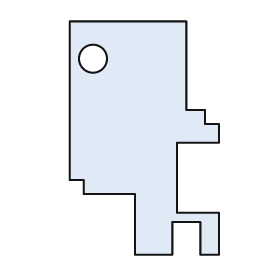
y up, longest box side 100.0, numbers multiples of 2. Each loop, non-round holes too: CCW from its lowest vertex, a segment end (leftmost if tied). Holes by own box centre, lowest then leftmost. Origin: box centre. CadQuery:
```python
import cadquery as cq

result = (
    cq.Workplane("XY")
    .moveTo(-4.0, -50.0)
    .lineTo(12.0, -50.0)
    .lineTo(12.0, -36.0)
    .lineTo(24.0, -36.0)
    .lineTo(24.0, -50.0)
    .lineTo(32.0, -50.0)
    .lineTo(32.0, -32.0)
    .lineTo(14.0, -32.0)
    .lineTo(14.0, -2.0)
    .lineTo(32.0, -2.0)
    .lineTo(32.0, 6.0)
    .lineTo(26.0, 6.0)
    .lineTo(26.0, 12.0)
    .lineTo(18.0, 12.0)
    .lineTo(18.0, 50.0)
    .lineTo(-32.0, 50.0)
    .lineTo(-32.0, -18.0)
    .lineTo(-26.0, -18.0)
    .lineTo(-26.0, -24.0)
    .lineTo(-4.0, -24.0)
    .close()
    .moveTo(-22.0, 34.0)
    .circle(6.0)
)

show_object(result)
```